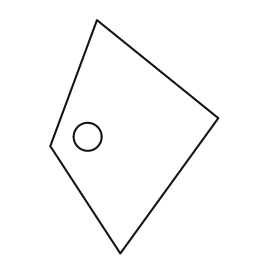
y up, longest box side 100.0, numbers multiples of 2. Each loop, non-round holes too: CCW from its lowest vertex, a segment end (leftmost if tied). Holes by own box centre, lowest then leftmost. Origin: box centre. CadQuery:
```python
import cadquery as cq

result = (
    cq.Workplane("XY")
    .moveTo(-6.0, -50.0)
    .lineTo(36.0, 8.0)
    .lineTo(-16.0, 50.0)
    .lineTo(-36.0, -4.0)
    .close()
    .moveTo(-20.0, 0.0)
    .circle(6.0)
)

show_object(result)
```